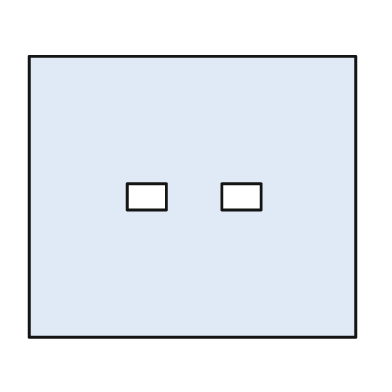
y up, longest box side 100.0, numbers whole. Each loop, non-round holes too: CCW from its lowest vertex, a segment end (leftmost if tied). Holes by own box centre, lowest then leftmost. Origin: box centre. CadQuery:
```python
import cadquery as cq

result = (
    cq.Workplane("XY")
    .moveTo(-50.0, -43.0)
    .lineTo(50.0, -43.0)
    .lineTo(50.0, 43.0)
    .lineTo(-50.0, 43.0)
    .close()
    .moveTo(-20.0, -4.0)
    .lineTo(-8.0, -4.0)
    .lineTo(-8.0, 4.0)
    .lineTo(-20.0, 4.0)
    .close()
    .moveTo(9.0, -4.0)
    .lineTo(21.0, -4.0)
    .lineTo(21.0, 4.0)
    .lineTo(9.0, 4.0)
    .close()
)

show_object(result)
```